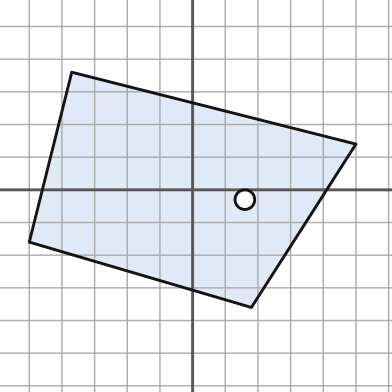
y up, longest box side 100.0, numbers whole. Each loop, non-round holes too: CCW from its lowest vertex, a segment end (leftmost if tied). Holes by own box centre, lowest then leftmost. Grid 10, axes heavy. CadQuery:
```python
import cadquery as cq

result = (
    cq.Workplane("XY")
    .moveTo(18.0, -36.0)
    .lineTo(50.0, 14.0)
    .lineTo(-37.0, 36.0)
    .lineTo(-50.0, -16.0)
    .close()
    .moveTo(16.0, -3.0)
    .circle(3.0)
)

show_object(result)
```